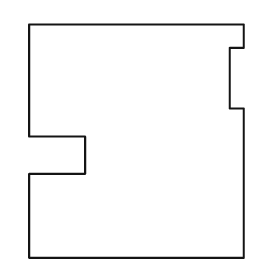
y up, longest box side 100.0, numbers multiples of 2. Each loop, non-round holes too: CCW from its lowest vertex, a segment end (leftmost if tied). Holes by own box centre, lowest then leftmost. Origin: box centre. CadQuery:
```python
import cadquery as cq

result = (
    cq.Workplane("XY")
    .moveTo(-46.0, -50.0)
    .lineTo(46.0, -50.0)
    .lineTo(46.0, 14.0)
    .lineTo(40.0, 14.0)
    .lineTo(40.0, 40.0)
    .lineTo(46.0, 40.0)
    .lineTo(46.0, 50.0)
    .lineTo(-46.0, 50.0)
    .lineTo(-46.0, 2.0)
    .lineTo(-22.0, 2.0)
    .lineTo(-22.0, -14.0)
    .lineTo(-46.0, -14.0)
    .close()
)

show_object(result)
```